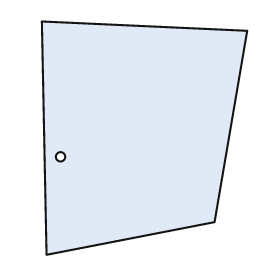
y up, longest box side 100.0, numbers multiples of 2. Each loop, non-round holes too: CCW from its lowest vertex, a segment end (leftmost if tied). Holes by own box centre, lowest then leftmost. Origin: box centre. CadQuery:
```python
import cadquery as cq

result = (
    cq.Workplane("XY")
    .moveTo(-42.0, -50.0)
    .lineTo(30.0, -36.0)
    .lineTo(44.0, 46.0)
    .lineTo(-44.0, 50.0)
    .close()
    .moveTo(-36.0, -8.0)
    .circle(2.0)
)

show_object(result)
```